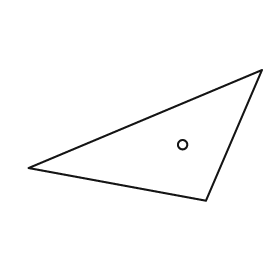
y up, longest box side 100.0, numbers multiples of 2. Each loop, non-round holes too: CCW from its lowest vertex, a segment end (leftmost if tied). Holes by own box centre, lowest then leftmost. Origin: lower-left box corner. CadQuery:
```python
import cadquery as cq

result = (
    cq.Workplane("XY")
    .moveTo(76.0, 0.0)
    .lineTo(100.0, 56.0)
    .lineTo(0.0, 14.0)
    .close()
    .moveTo(66.0, 24.0)
    .circle(2.0)
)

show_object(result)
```